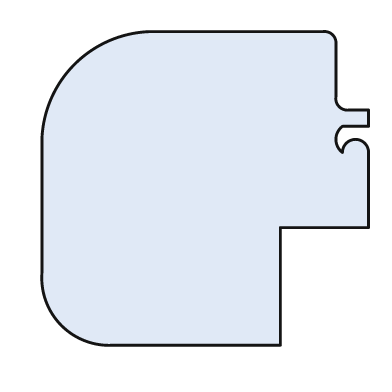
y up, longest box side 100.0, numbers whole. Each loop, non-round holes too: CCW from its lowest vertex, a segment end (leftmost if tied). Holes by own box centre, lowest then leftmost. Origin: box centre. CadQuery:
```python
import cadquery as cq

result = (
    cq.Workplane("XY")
    .moveTo(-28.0, -48.0)
    .lineTo(23.0, -48.0)
    .lineTo(23.0, -12.0)
    .lineTo(50.0, -12.0)
    .lineTo(50.0, 11.0)
    .threePointArc((46.0, 15.0), (42.0, 11.0))
    .threePointArc((40.0, 15.0), (42.0, 19.0))
    .lineTo(50.0, 19.0)
    .lineTo(50.0, 24.0)
    .lineTo(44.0, 24.0)
    .threePointArc((41.0, 25.0), (40.0, 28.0))
    .lineTo(40.0, 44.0)
    .threePointArc((39.0, 47.0), (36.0, 48.0))
    .lineTo(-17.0, 48.0)
    .threePointArc((-40.0, 38.0), (-50.0, 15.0))
    .lineTo(-50.0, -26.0)
    .threePointArc((-44.0, -42.0), (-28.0, -48.0))
    .close()
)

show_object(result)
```